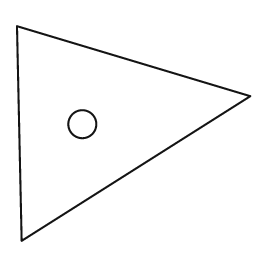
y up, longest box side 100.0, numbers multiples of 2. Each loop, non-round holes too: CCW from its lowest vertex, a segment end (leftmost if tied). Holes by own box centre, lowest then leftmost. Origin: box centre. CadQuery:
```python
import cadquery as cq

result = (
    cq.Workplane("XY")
    .moveTo(-48.0, -46.0)
    .lineTo(50.0, 16.0)
    .lineTo(-50.0, 46.0)
    .close()
    .moveTo(-22.0, 4.0)
    .circle(6.0)
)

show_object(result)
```